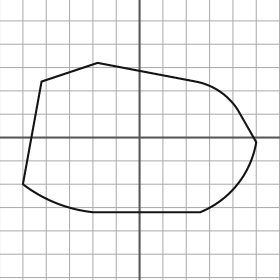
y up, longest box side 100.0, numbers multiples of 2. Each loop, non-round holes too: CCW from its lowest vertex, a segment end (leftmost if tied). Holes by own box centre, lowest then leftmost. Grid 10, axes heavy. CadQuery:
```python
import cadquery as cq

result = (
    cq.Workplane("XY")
    .moveTo(-20.0, -32.0)
    .lineTo(26.0, -32.0)
    .threePointArc((42.0, -20.0), (50.0, -2.0))
    .lineTo(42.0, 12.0)
    .threePointArc((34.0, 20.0), (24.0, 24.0))
    .lineTo(-18.0, 32.0)
    .lineTo(-42.0, 24.0)
    .lineTo(-50.0, -20.0)
    .threePointArc((-36.0, -28.0), (-20.0, -32.0))
    .close()
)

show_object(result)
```